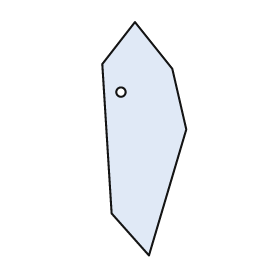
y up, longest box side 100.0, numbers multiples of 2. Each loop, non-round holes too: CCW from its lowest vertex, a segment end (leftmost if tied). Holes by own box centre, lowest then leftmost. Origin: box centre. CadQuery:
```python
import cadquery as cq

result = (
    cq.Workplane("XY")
    .moveTo(2.0, -50.0)
    .lineTo(18.0, 4.0)
    .lineTo(12.0, 30.0)
    .lineTo(-4.0, 50.0)
    .lineTo(-18.0, 32.0)
    .lineTo(-14.0, -32.0)
    .close()
    .moveTo(-10.0, 20.0)
    .circle(2.0)
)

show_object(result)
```